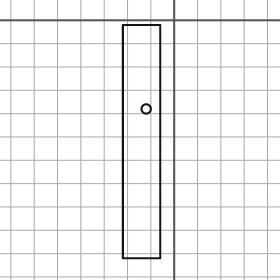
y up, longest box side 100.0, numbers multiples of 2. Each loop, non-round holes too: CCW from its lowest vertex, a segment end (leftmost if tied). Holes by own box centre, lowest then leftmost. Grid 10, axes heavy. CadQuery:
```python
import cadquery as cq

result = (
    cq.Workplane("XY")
    .moveTo(-22.0, -102.0)
    .lineTo(-6.0, -102.0)
    .lineTo(-6.0, -2.0)
    .lineTo(-22.0, -2.0)
    .close()
    .moveTo(-12.0, -38.0)
    .circle(2.0)
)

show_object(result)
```